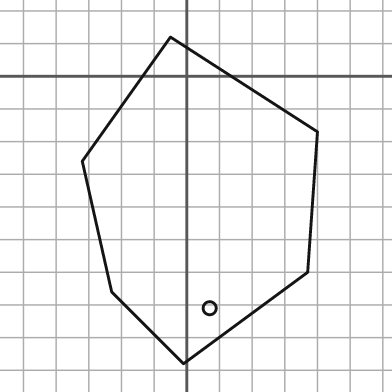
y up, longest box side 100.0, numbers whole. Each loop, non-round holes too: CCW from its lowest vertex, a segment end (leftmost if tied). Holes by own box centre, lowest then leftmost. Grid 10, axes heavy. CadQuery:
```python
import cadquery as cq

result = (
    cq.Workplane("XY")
    .moveTo(-1.0, -88.0)
    .lineTo(37.0, -60.0)
    .lineTo(40.0, -17.0)
    .lineTo(-5.0, 12.0)
    .lineTo(-32.0, -26.0)
    .lineTo(-23.0, -66.0)
    .close()
    .moveTo(7.0, -71.0)
    .circle(2.0)
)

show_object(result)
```